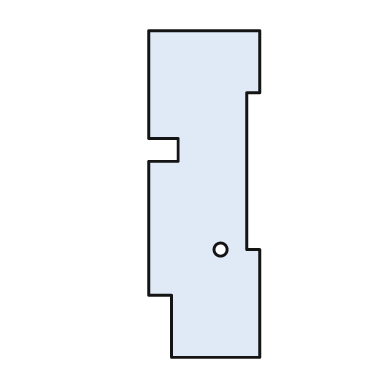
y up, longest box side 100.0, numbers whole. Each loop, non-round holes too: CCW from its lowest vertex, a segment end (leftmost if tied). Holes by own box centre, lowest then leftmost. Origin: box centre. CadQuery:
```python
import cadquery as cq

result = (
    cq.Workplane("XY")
    .moveTo(-10.0, -50.0)
    .lineTo(17.0, -50.0)
    .lineTo(17.0, -17.0)
    .lineTo(13.0, -17.0)
    .lineTo(13.0, 31.0)
    .lineTo(17.0, 31.0)
    .lineTo(17.0, 50.0)
    .lineTo(-17.0, 50.0)
    .lineTo(-17.0, 17.0)
    .lineTo(-8.0, 17.0)
    .lineTo(-8.0, 10.0)
    .lineTo(-17.0, 10.0)
    .lineTo(-17.0, -31.0)
    .lineTo(-10.0, -31.0)
    .close()
    .moveTo(5.0, -17.0)
    .circle(2.0)
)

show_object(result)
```